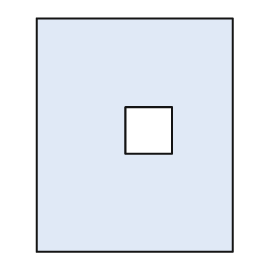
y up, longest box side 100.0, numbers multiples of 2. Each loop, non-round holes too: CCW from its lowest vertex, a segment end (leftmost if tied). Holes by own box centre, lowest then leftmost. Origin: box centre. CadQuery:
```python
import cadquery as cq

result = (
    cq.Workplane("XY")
    .moveTo(-42.0, -50.0)
    .lineTo(42.0, -50.0)
    .lineTo(42.0, 50.0)
    .lineTo(-42.0, 50.0)
    .close()
    .moveTo(-4.0, -8.0)
    .lineTo(16.0, -8.0)
    .lineTo(16.0, 12.0)
    .lineTo(-4.0, 12.0)
    .close()
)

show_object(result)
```